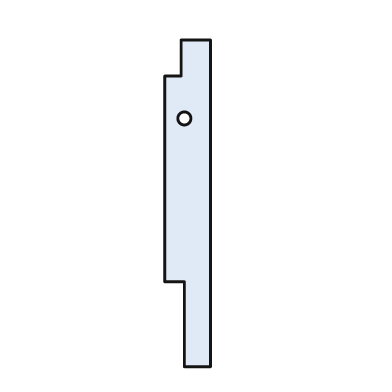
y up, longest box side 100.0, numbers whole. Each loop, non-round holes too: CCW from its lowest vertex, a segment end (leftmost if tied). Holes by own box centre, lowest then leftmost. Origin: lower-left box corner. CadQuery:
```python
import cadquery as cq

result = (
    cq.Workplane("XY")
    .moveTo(6.0, 0.0)
    .lineTo(14.0, 0.0)
    .lineTo(14.0, 100.0)
    .lineTo(5.0, 100.0)
    .lineTo(5.0, 89.0)
    .lineTo(0.0, 89.0)
    .lineTo(0.0, 26.0)
    .lineTo(6.0, 26.0)
    .close()
    .moveTo(6.0, 76.0)
    .circle(2.0)
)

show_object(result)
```